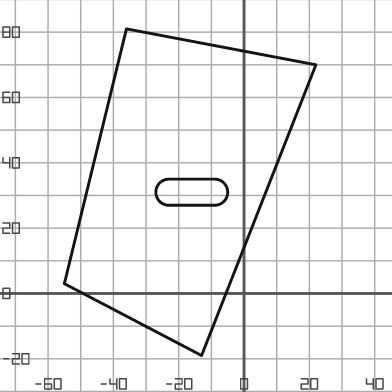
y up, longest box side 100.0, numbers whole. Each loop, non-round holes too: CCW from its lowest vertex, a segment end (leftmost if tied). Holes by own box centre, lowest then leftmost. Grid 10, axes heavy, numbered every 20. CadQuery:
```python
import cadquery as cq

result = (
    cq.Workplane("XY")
    .moveTo(-13.0, -19.0)
    .lineTo(22.0, 70.0)
    .lineTo(-36.0, 81.0)
    .lineTo(-55.0, 3.0)
    .close()
    .moveTo(-23.0, 27.0)
    .lineTo(-9.0, 27.0)
    .threePointArc((-5.0, 31.0), (-9.0, 35.0))
    .lineTo(-23.0, 35.0)
    .threePointArc((-27.0, 31.0), (-23.0, 27.0))
    .close()
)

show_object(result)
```